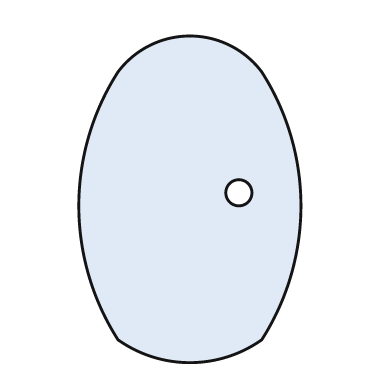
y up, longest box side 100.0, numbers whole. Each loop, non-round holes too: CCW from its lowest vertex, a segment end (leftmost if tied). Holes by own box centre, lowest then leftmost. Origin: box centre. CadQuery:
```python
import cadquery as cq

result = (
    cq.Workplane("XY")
    .moveTo(-22.0, -43.0)
    .threePointArc((0.0, -50.0), (22.0, -43.0))
    .threePointArc((34.0, -2.0), (22.0, 39.0))
    .threePointArc((0.0, 50.0), (-22.0, 39.0))
    .threePointArc((-34.0, -2.0), (-22.0, -43.0))
    .close()
    .moveTo(15.0, 2.0)
    .circle(4.0)
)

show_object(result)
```